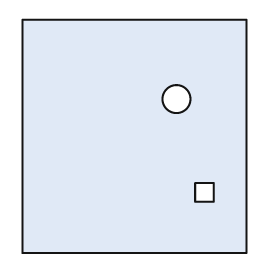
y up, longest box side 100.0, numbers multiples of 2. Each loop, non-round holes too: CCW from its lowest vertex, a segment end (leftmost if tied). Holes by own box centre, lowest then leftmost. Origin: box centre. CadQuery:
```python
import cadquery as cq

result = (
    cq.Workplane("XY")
    .moveTo(-48.0, -50.0)
    .lineTo(48.0, -50.0)
    .lineTo(48.0, 50.0)
    .lineTo(-48.0, 50.0)
    .close()
    .moveTo(26.0, -28.0)
    .lineTo(34.0, -28.0)
    .lineTo(34.0, -20.0)
    .lineTo(26.0, -20.0)
    .close()
    .moveTo(18.0, 16.0)
    .circle(6.0)
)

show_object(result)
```